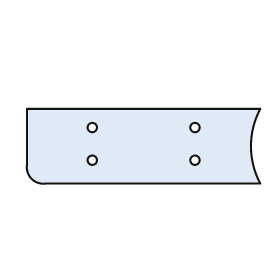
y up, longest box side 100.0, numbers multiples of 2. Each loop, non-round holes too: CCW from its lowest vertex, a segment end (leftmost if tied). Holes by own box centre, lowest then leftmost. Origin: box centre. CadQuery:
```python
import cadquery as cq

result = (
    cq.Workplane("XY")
    .moveTo(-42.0, -16.0)
    .lineTo(50.0, -16.0)
    .threePointArc((46.0, 0.0), (50.0, 16.0))
    .lineTo(-50.0, 16.0)
    .lineTo(-50.0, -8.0)
    .threePointArc((-48.0, -14.0), (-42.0, -16.0))
    .close()
    .moveTo(-22.0, -6.0)
    .circle(2.0)
    .moveTo(22.0, -6.0)
    .circle(2.0)
    .moveTo(-22.0, 8.0)
    .circle(2.0)
    .moveTo(22.0, 8.0)
    .circle(2.0)
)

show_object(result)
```